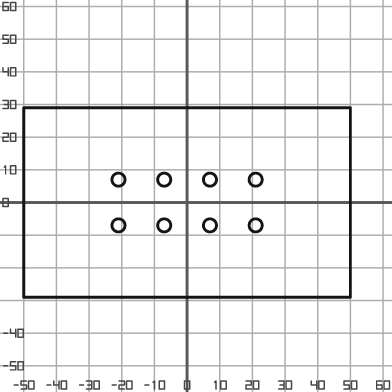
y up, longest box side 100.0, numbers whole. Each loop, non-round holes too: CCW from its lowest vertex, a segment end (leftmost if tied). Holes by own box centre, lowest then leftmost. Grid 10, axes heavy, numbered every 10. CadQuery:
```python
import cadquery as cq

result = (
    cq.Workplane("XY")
    .moveTo(-50.0, -29.0)
    .lineTo(50.0, -29.0)
    .lineTo(50.0, 29.0)
    .lineTo(-50.0, 29.0)
    .close()
    .moveTo(-21.0, -7.0)
    .circle(2.0)
    .moveTo(-7.0, -7.0)
    .circle(2.0)
    .moveTo(7.0, -7.0)
    .circle(2.0)
    .moveTo(21.0, -7.0)
    .circle(2.0)
    .moveTo(-21.0, 7.0)
    .circle(2.0)
    .moveTo(-7.0, 7.0)
    .circle(2.0)
    .moveTo(7.0, 7.0)
    .circle(2.0)
    .moveTo(21.0, 7.0)
    .circle(2.0)
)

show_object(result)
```